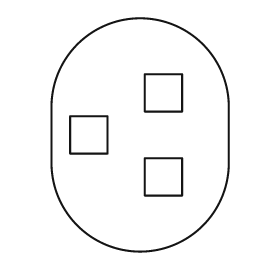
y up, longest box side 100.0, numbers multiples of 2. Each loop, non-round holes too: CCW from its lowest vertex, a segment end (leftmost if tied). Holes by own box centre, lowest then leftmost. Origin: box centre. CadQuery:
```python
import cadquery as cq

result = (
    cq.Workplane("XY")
    .moveTo(-38.0, -12.0)
    .threePointArc((0.0, -50.0), (38.0, -12.0))
    .lineTo(38.0, 12.0)
    .threePointArc((0.0, 50.0), (-38.0, 12.0))
    .close()
    .moveTo(2.0, -26.0)
    .lineTo(18.0, -26.0)
    .lineTo(18.0, -10.0)
    .lineTo(2.0, -10.0)
    .close()
    .moveTo(-30.0, -8.0)
    .lineTo(-14.0, -8.0)
    .lineTo(-14.0, 8.0)
    .lineTo(-30.0, 8.0)
    .close()
    .moveTo(2.0, 10.0)
    .lineTo(18.0, 10.0)
    .lineTo(18.0, 26.0)
    .lineTo(2.0, 26.0)
    .close()
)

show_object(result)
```